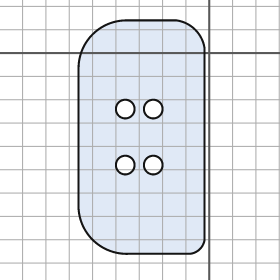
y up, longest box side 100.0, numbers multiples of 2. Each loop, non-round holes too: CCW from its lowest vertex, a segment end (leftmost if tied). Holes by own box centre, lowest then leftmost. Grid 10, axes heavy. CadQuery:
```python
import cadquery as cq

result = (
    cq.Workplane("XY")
    .moveTo(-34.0, -86.0)
    .lineTo(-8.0, -86.0)
    .threePointArc((-4.0, -84.0), (-2.0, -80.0))
    .lineTo(-2.0, 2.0)
    .threePointArc((-6.0, 10.0), (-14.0, 14.0))
    .lineTo(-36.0, 14.0)
    .threePointArc((-50.0, 8.0), (-56.0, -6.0))
    .lineTo(-56.0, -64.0)
    .threePointArc((-50.0, -80.0), (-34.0, -86.0))
    .close()
    .moveTo(-36.0, -48.0)
    .circle(4.0)
    .moveTo(-24.0, -48.0)
    .circle(4.0)
    .moveTo(-36.0, -24.0)
    .circle(4.0)
    .moveTo(-24.0, -24.0)
    .circle(4.0)
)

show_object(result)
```